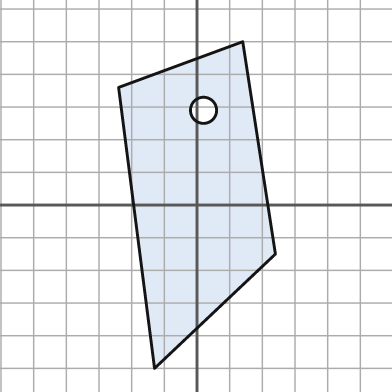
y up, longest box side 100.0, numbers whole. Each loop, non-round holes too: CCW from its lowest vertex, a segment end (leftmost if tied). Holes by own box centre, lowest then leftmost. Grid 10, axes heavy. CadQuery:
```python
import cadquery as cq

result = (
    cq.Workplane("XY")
    .moveTo(-13.0, -50.0)
    .lineTo(24.0, -15.0)
    .lineTo(14.0, 50.0)
    .lineTo(-24.0, 36.0)
    .close()
    .moveTo(2.0, 29.0)
    .circle(4.0)
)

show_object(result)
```